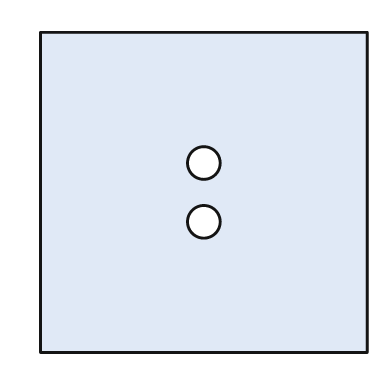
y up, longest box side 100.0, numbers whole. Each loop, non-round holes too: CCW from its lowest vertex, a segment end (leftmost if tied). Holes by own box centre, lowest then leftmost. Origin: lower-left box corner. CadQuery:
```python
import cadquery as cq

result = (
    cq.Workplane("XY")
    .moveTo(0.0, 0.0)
    .lineTo(100.0, 0.0)
    .lineTo(100.0, 98.0)
    .lineTo(0.0, 98.0)
    .close()
    .moveTo(50.0, 40.0)
    .circle(5.0)
    .moveTo(50.0, 58.0)
    .circle(5.0)
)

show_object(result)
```